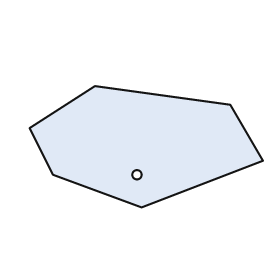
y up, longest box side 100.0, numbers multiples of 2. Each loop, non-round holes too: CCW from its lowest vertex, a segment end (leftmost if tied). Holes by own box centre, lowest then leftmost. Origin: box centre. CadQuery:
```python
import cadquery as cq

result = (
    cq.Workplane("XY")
    .moveTo(-2.0, -26.0)
    .lineTo(50.0, -6.0)
    .lineTo(36.0, 18.0)
    .lineTo(-22.0, 26.0)
    .lineTo(-50.0, 8.0)
    .lineTo(-40.0, -12.0)
    .close()
    .moveTo(-4.0, -12.0)
    .circle(2.0)
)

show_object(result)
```